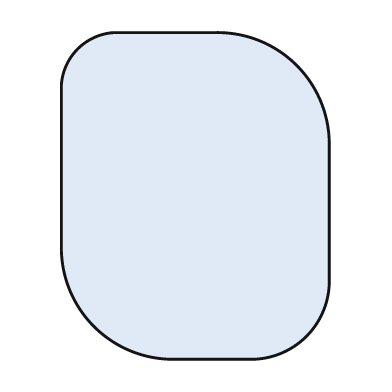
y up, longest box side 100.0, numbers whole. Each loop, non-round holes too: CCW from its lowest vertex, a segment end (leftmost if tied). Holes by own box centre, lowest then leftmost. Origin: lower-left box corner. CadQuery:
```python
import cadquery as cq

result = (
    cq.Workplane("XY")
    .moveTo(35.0, 0.0)
    .lineTo(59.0, 0.0)
    .threePointArc((75.0, 7.0), (82.0, 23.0))
    .lineTo(82.0, 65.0)
    .threePointArc((72.0, 90.0), (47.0, 100.0))
    .lineTo(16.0, 100.0)
    .threePointArc((5.0, 95.0), (0.0, 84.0))
    .lineTo(0.0, 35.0)
    .threePointArc((10.0, 10.0), (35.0, 0.0))
    .close()
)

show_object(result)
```